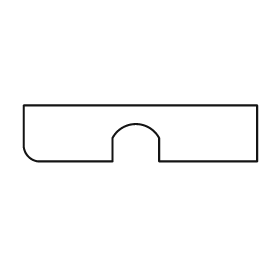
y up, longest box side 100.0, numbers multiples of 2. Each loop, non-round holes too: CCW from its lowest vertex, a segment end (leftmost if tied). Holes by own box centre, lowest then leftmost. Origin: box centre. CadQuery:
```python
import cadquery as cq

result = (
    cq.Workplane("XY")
    .moveTo(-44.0, -12.0)
    .lineTo(-12.0, -12.0)
    .lineTo(-12.0, -2.0)
    .threePointArc((-2.0, 4.0), (8.0, -2.0))
    .lineTo(8.0, -12.0)
    .lineTo(50.0, -12.0)
    .lineTo(50.0, 12.0)
    .lineTo(-50.0, 12.0)
    .lineTo(-50.0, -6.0)
    .threePointArc((-48.0, -10.0), (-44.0, -12.0))
    .close()
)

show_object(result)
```